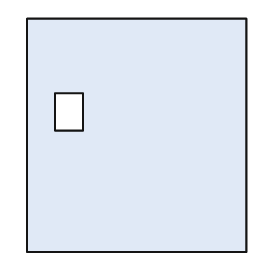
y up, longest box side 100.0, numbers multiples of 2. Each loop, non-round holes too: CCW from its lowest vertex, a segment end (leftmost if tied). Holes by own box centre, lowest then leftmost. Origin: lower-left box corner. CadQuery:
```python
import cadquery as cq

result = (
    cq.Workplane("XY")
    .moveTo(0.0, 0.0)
    .lineTo(94.0, 0.0)
    .lineTo(94.0, 100.0)
    .lineTo(0.0, 100.0)
    .close()
    .moveTo(12.0, 52.0)
    .lineTo(24.0, 52.0)
    .lineTo(24.0, 68.0)
    .lineTo(12.0, 68.0)
    .close()
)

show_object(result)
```